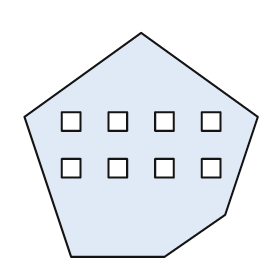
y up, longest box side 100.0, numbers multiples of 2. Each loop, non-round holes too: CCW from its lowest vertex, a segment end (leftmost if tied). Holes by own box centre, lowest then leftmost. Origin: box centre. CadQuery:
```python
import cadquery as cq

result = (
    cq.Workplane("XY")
    .moveTo(-30.0, -48.0)
    .lineTo(10.0, -48.0)
    .lineTo(36.0, -30.0)
    .lineTo(50.0, 12.0)
    .lineTo(0.0, 48.0)
    .lineTo(-50.0, 12.0)
    .close()
    .moveTo(-34.0, -14.0)
    .lineTo(-26.0, -14.0)
    .lineTo(-26.0, -6.0)
    .lineTo(-34.0, -6.0)
    .close()
    .moveTo(-14.0, -14.0)
    .lineTo(-6.0, -14.0)
    .lineTo(-6.0, -6.0)
    .lineTo(-14.0, -6.0)
    .close()
    .moveTo(6.0, -14.0)
    .lineTo(14.0, -14.0)
    .lineTo(14.0, -6.0)
    .lineTo(6.0, -6.0)
    .close()
    .moveTo(26.0, -14.0)
    .lineTo(34.0, -14.0)
    .lineTo(34.0, -6.0)
    .lineTo(26.0, -6.0)
    .close()
    .moveTo(-34.0, 6.0)
    .lineTo(-26.0, 6.0)
    .lineTo(-26.0, 14.0)
    .lineTo(-34.0, 14.0)
    .close()
    .moveTo(-14.0, 6.0)
    .lineTo(-6.0, 6.0)
    .lineTo(-6.0, 14.0)
    .lineTo(-14.0, 14.0)
    .close()
    .moveTo(6.0, 6.0)
    .lineTo(14.0, 6.0)
    .lineTo(14.0, 14.0)
    .lineTo(6.0, 14.0)
    .close()
    .moveTo(26.0, 6.0)
    .lineTo(34.0, 6.0)
    .lineTo(34.0, 14.0)
    .lineTo(26.0, 14.0)
    .close()
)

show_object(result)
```